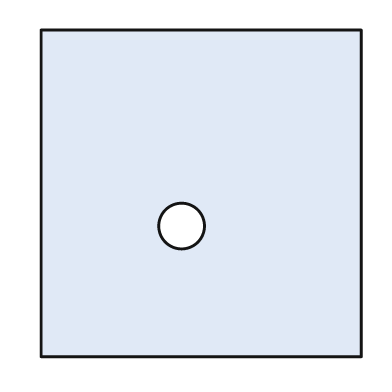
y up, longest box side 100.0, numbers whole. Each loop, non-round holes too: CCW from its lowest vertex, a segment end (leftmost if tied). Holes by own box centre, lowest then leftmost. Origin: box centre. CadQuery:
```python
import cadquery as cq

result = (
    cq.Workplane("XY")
    .moveTo(-49.0, -50.0)
    .lineTo(49.0, -50.0)
    .lineTo(49.0, 50.0)
    .lineTo(-49.0, 50.0)
    .close()
    .moveTo(-6.0, -10.0)
    .circle(7.0)
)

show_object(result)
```